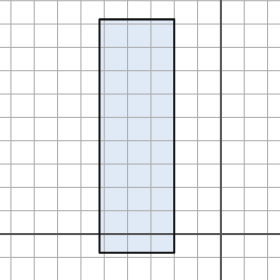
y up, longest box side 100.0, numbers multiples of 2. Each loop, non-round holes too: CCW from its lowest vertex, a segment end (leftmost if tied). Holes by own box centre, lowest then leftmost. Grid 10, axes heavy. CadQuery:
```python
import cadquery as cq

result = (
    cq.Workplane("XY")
    .moveTo(-52.0, -8.0)
    .lineTo(-20.0, -8.0)
    .lineTo(-20.0, 92.0)
    .lineTo(-52.0, 92.0)
    .close()
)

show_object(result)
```